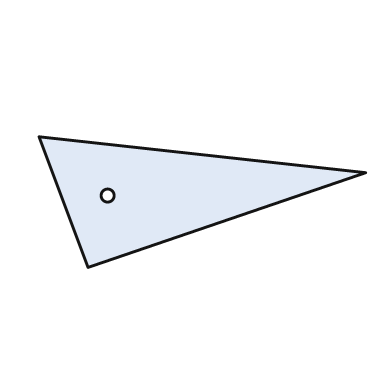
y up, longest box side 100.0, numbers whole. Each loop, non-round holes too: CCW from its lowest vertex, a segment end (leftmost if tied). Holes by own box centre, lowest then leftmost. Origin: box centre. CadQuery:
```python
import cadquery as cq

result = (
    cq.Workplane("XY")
    .moveTo(-35.0, -20.0)
    .lineTo(50.0, 9.0)
    .lineTo(-50.0, 20.0)
    .close()
    .moveTo(-29.0, 2.0)
    .circle(2.0)
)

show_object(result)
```